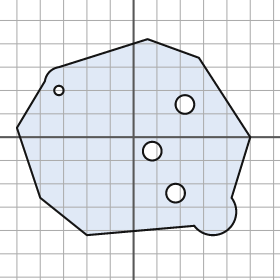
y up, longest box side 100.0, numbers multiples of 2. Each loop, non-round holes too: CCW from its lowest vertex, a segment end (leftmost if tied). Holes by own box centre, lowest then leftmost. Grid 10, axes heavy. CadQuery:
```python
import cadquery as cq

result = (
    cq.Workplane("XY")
    .moveTo(-20.0, -42.0)
    .lineTo(26.0, -38.0)
    .threePointArc((40.0, -40.0), (42.0, -26.0))
    .lineTo(50.0, 0.0)
    .lineTo(28.0, 34.0)
    .lineTo(6.0, 42.0)
    .lineTo(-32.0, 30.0)
    .threePointArc((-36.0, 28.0), (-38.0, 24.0))
    .lineTo(-50.0, 4.0)
    .lineTo(-40.0, -26.0)
    .close()
    .moveTo(18.0, -24.0)
    .circle(4.0)
    .moveTo(8.0, -6.0)
    .circle(4.0)
    .moveTo(22.0, 14.0)
    .circle(4.0)
    .moveTo(-32.0, 20.0)
    .circle(2.0)
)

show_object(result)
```